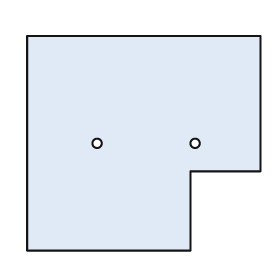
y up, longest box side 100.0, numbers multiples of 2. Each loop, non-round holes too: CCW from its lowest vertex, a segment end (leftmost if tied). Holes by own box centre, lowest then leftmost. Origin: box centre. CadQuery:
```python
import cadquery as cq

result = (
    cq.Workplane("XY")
    .moveTo(-50.0, -46.0)
    .lineTo(20.0, -46.0)
    .lineTo(20.0, -12.0)
    .lineTo(50.0, -12.0)
    .lineTo(50.0, 46.0)
    .lineTo(-50.0, 46.0)
    .close()
    .moveTo(-20.0, 0.0)
    .circle(2.0)
    .moveTo(22.0, 0.0)
    .circle(2.0)
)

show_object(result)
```